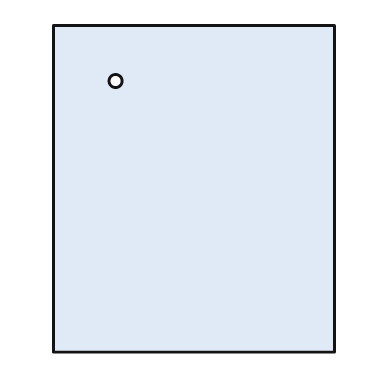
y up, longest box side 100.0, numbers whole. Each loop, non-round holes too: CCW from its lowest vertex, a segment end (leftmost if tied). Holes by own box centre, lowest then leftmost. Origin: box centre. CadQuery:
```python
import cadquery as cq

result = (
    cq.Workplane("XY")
    .moveTo(-43.0, -50.0)
    .lineTo(43.0, -50.0)
    .lineTo(43.0, 50.0)
    .lineTo(-43.0, 50.0)
    .close()
    .moveTo(-24.0, 33.0)
    .circle(2.0)
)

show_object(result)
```